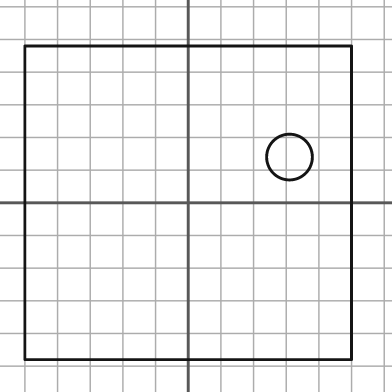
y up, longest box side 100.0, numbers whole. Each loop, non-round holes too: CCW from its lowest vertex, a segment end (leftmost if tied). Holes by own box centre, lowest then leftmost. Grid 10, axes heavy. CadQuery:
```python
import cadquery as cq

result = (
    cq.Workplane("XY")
    .moveTo(-50.0, -48.0)
    .lineTo(50.0, -48.0)
    .lineTo(50.0, 48.0)
    .lineTo(-50.0, 48.0)
    .close()
    .moveTo(31.0, 14.0)
    .circle(7.0)
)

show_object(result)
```